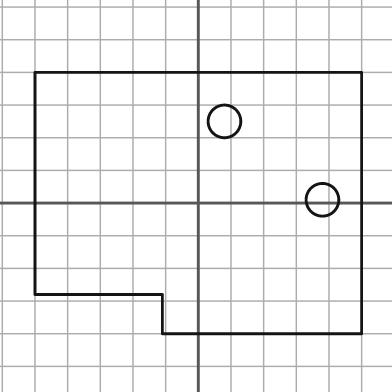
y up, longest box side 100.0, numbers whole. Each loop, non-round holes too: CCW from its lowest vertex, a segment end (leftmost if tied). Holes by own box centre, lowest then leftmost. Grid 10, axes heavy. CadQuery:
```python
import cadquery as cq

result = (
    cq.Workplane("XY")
    .moveTo(-11.0, -40.0)
    .lineTo(50.0, -40.0)
    .lineTo(50.0, 40.0)
    .lineTo(-50.0, 40.0)
    .lineTo(-50.0, -28.0)
    .lineTo(-11.0, -28.0)
    .close()
    .moveTo(38.0, 1.0)
    .circle(5.0)
    .moveTo(8.0, 25.0)
    .circle(5.0)
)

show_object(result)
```